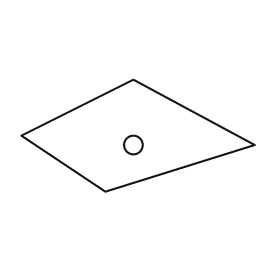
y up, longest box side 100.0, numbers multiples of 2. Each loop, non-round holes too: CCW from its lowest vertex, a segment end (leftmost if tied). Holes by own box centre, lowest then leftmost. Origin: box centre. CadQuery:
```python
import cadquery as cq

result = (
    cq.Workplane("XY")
    .moveTo(-14.0, -24.0)
    .lineTo(50.0, -4.0)
    .lineTo(-2.0, 24.0)
    .lineTo(-50.0, 0.0)
    .close()
    .moveTo(-2.0, -4.0)
    .circle(4.0)
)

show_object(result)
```